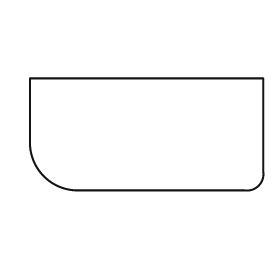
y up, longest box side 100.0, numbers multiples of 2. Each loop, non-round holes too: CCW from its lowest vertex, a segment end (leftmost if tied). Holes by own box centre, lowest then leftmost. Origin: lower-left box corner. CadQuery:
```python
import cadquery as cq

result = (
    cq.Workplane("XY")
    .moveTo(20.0, 0.0)
    .lineTo(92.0, 0.0)
    .threePointArc((98.0, 2.0), (100.0, 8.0))
    .lineTo(100.0, 48.0)
    .lineTo(0.0, 48.0)
    .lineTo(0.0, 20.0)
    .threePointArc((6.0, 6.0), (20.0, 0.0))
    .close()
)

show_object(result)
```